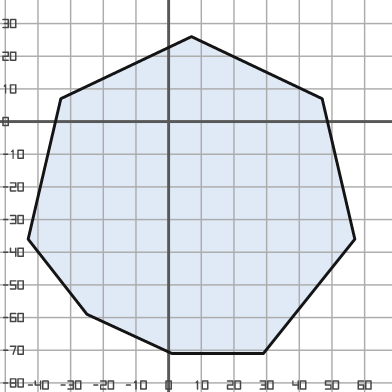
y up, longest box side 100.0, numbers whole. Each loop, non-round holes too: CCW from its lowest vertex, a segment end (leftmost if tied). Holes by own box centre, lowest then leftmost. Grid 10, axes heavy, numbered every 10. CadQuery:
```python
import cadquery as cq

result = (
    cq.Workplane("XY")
    .moveTo(1.0, -71.0)
    .lineTo(29.0, -71.0)
    .lineTo(57.0, -36.0)
    .lineTo(47.0, 7.0)
    .lineTo(7.0, 26.0)
    .lineTo(-33.0, 7.0)
    .lineTo(-43.0, -36.0)
    .lineTo(-25.0, -59.0)
    .close()
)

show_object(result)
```